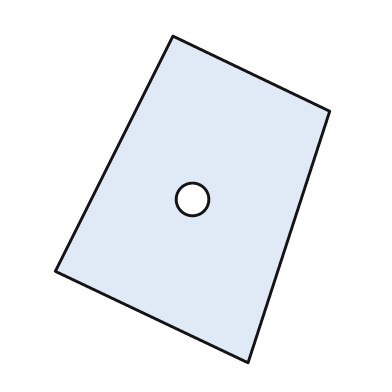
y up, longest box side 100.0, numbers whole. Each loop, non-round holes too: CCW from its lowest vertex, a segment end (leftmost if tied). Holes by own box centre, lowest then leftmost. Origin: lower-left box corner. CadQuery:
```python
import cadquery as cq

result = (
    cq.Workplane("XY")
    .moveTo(59.0, 0.0)
    .lineTo(84.0, 77.0)
    .lineTo(36.0, 100.0)
    .lineTo(0.0, 28.0)
    .close()
    .moveTo(42.0, 50.0)
    .circle(5.0)
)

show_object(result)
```